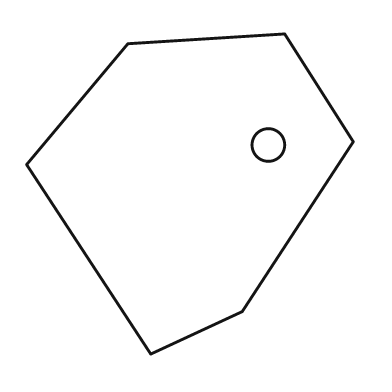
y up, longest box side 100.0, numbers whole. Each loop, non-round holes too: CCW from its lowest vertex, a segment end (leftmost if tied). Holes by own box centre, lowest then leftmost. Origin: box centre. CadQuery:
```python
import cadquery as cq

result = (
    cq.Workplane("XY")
    .moveTo(-12.0, -49.0)
    .lineTo(16.0, -36.0)
    .lineTo(50.0, 16.0)
    .lineTo(29.0, 49.0)
    .lineTo(-19.0, 46.0)
    .lineTo(-50.0, 9.0)
    .close()
    .moveTo(24.0, 15.0)
    .circle(5.0)
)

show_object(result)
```